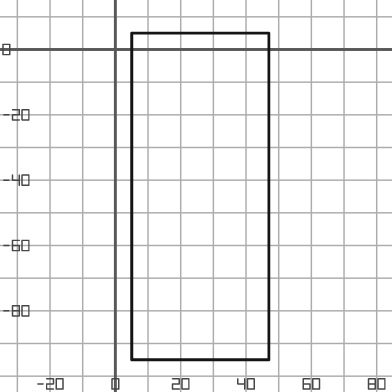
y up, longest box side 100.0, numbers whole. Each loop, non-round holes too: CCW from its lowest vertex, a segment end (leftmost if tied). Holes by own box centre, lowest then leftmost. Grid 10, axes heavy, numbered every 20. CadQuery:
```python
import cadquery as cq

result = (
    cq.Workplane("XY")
    .moveTo(5.0, -95.0)
    .lineTo(47.0, -95.0)
    .lineTo(47.0, 5.0)
    .lineTo(5.0, 5.0)
    .close()
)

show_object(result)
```